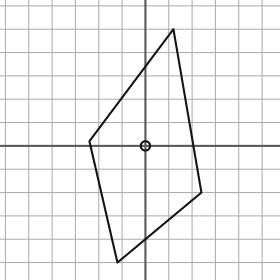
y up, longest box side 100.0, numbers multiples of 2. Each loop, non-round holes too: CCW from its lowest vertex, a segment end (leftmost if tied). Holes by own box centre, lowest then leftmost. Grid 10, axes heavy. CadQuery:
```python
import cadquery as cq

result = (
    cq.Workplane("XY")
    .moveTo(-12.0, -50.0)
    .lineTo(24.0, -20.0)
    .lineTo(12.0, 50.0)
    .lineTo(-24.0, 2.0)
    .close()
    .moveTo(0.0, 0.0)
    .circle(2.0)
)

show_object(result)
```